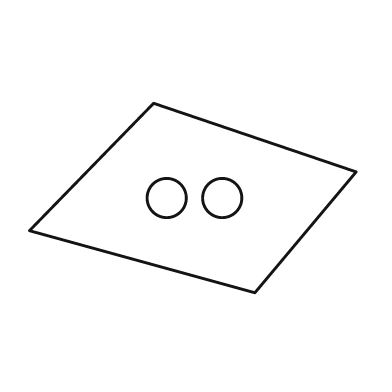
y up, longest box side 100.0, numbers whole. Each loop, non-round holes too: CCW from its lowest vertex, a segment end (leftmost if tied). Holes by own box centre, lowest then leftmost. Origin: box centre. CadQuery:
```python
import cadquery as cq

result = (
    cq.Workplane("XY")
    .moveTo(19.0, -29.0)
    .lineTo(50.0, 8.0)
    .lineTo(-12.0, 29.0)
    .lineTo(-50.0, -10.0)
    .close()
    .moveTo(-8.0, 0.0)
    .circle(6.0)
    .moveTo(9.0, 0.0)
    .circle(6.0)
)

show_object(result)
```